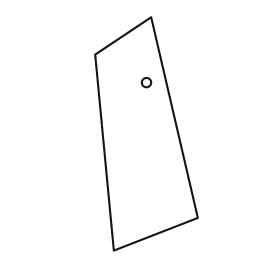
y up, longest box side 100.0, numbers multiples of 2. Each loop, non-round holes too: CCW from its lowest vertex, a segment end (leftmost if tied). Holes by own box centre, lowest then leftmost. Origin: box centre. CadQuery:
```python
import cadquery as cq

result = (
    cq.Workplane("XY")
    .moveTo(-14.0, -50.0)
    .lineTo(22.0, -36.0)
    .lineTo(2.0, 50.0)
    .lineTo(-22.0, 34.0)
    .close()
    .moveTo(0.0, 22.0)
    .circle(2.0)
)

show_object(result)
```